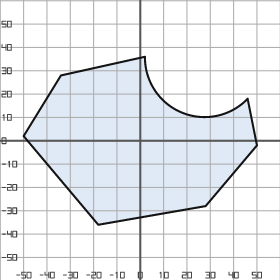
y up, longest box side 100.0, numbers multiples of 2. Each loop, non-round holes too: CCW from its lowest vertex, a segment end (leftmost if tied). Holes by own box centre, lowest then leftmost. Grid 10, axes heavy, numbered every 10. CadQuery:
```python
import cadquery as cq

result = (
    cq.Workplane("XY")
    .moveTo(-18.0, -36.0)
    .lineTo(28.0, -28.0)
    .lineTo(50.0, -2.0)
    .lineTo(46.0, 18.0)
    .threePointArc((18.0, 12.0), (2.0, 36.0))
    .lineTo(-34.0, 28.0)
    .lineTo(-50.0, 2.0)
    .close()
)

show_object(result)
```